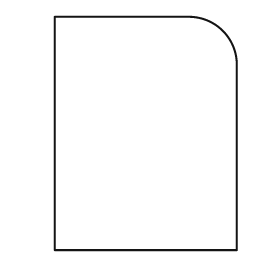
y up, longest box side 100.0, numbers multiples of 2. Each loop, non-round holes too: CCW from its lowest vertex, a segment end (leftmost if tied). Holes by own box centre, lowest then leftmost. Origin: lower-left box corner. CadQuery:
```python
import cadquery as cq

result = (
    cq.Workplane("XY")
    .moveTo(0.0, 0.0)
    .lineTo(78.0, 0.0)
    .lineTo(78.0, 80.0)
    .threePointArc((72.0, 94.0), (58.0, 100.0))
    .lineTo(0.0, 100.0)
    .close()
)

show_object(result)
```